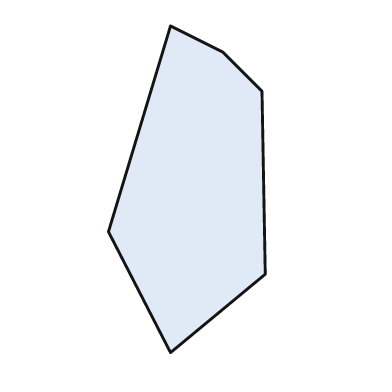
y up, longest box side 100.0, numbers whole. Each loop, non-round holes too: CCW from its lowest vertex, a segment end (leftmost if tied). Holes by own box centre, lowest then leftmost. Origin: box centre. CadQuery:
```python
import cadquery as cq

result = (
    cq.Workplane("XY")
    .moveTo(-5.0, -50.0)
    .lineTo(24.0, -26.0)
    .lineTo(23.0, 30.0)
    .lineTo(11.0, 42.0)
    .lineTo(-5.0, 50.0)
    .lineTo(-24.0, -13.0)
    .close()
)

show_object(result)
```